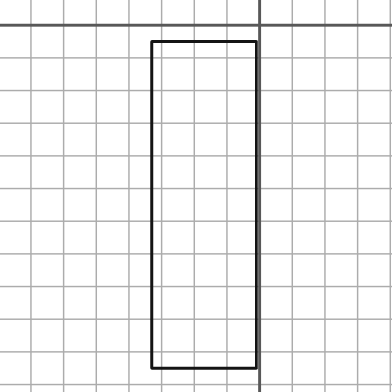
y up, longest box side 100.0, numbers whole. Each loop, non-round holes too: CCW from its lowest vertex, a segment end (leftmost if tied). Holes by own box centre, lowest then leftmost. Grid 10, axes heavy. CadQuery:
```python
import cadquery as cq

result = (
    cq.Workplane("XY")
    .moveTo(-33.0, -105.0)
    .lineTo(-1.0, -105.0)
    .lineTo(-1.0, -5.0)
    .lineTo(-33.0, -5.0)
    .close()
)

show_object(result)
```